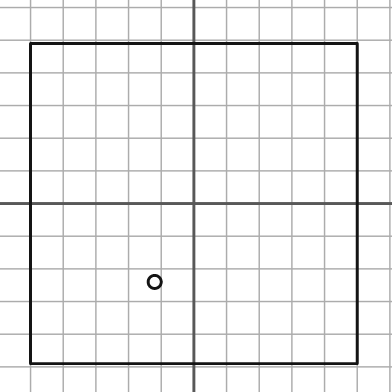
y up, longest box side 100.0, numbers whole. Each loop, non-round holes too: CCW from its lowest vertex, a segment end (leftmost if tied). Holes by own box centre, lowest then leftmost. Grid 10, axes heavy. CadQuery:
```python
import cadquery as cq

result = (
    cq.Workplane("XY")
    .moveTo(-50.0, -49.0)
    .lineTo(50.0, -49.0)
    .lineTo(50.0, 49.0)
    .lineTo(-50.0, 49.0)
    .close()
    .moveTo(-12.0, -24.0)
    .circle(2.0)
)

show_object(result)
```